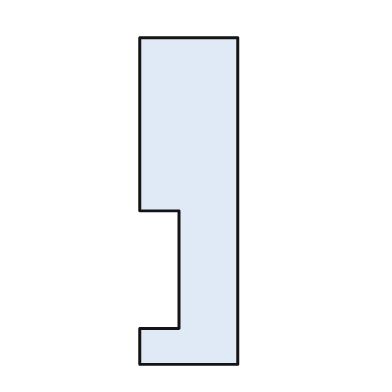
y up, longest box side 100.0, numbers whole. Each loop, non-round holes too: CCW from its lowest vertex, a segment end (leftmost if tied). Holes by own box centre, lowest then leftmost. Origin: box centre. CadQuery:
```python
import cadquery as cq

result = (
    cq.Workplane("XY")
    .moveTo(-15.0, -50.0)
    .lineTo(15.0, -50.0)
    .lineTo(15.0, 50.0)
    .lineTo(-15.0, 50.0)
    .lineTo(-15.0, -3.0)
    .lineTo(-3.0, -3.0)
    .lineTo(-3.0, -39.0)
    .lineTo(-15.0, -39.0)
    .close()
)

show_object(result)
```